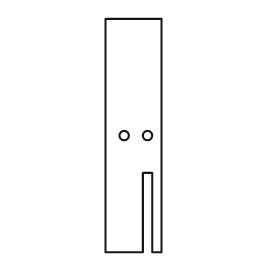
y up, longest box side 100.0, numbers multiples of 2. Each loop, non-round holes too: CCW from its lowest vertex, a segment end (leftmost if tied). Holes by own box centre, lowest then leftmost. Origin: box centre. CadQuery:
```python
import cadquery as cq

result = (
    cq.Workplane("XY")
    .moveTo(-12.0, -50.0)
    .lineTo(4.0, -50.0)
    .lineTo(4.0, -16.0)
    .lineTo(8.0, -16.0)
    .lineTo(8.0, -50.0)
    .lineTo(12.0, -50.0)
    .lineTo(12.0, 50.0)
    .lineTo(-12.0, 50.0)
    .close()
    .moveTo(-4.0, 0.0)
    .circle(2.0)
    .moveTo(6.0, 0.0)
    .circle(2.0)
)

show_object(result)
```